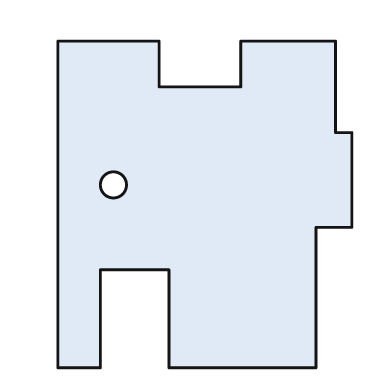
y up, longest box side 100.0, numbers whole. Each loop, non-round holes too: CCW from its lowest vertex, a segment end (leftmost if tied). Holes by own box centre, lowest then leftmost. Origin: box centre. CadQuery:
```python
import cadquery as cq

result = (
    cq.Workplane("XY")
    .moveTo(-45.0, -50.0)
    .lineTo(-32.0, -50.0)
    .lineTo(-32.0, -20.0)
    .lineTo(-11.0, -20.0)
    .lineTo(-11.0, -50.0)
    .lineTo(34.0, -50.0)
    .lineTo(34.0, -7.0)
    .lineTo(45.0, -7.0)
    .lineTo(45.0, 22.0)
    .lineTo(40.0, 22.0)
    .lineTo(40.0, 50.0)
    .lineTo(11.0, 50.0)
    .lineTo(11.0, 36.0)
    .lineTo(-14.0, 36.0)
    .lineTo(-14.0, 50.0)
    .lineTo(-45.0, 50.0)
    .close()
    .moveTo(-28.0, 6.0)
    .circle(4.0)
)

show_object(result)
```